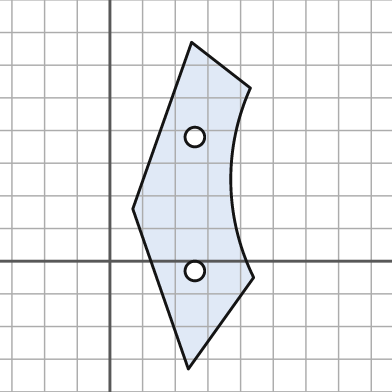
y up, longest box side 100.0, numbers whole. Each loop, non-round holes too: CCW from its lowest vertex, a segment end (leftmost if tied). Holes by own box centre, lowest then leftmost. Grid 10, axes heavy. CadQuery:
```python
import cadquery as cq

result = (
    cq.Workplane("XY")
    .moveTo(24.0, -33.0)
    .lineTo(44.0, -5.0)
    .threePointArc((37.0, 24.0), (43.0, 53.0))
    .lineTo(25.0, 67.0)
    .lineTo(7.0, 16.0)
    .close()
    .moveTo(26.0, -3.0)
    .circle(3.0)
    .moveTo(26.0, 38.0)
    .circle(3.0)
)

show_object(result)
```